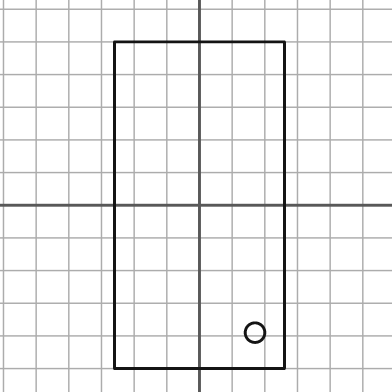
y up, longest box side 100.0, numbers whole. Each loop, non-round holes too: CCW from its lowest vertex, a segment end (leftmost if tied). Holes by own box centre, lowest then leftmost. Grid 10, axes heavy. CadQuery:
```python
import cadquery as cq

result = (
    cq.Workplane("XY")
    .moveTo(-26.0, -50.0)
    .lineTo(26.0, -50.0)
    .lineTo(26.0, 50.0)
    .lineTo(-26.0, 50.0)
    .close()
    .moveTo(17.0, -39.0)
    .circle(3.0)
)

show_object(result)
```